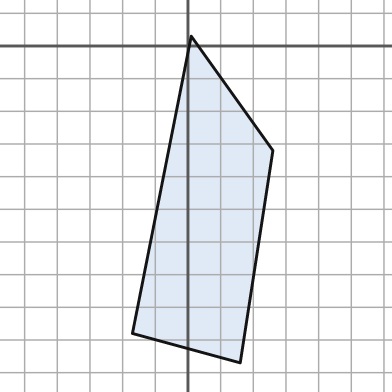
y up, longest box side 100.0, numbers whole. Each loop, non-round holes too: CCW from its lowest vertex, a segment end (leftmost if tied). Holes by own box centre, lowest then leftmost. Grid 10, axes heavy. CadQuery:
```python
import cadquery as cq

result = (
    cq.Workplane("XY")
    .moveTo(16.0, -97.0)
    .lineTo(26.0, -32.0)
    .lineTo(1.0, 3.0)
    .lineTo(-17.0, -88.0)
    .close()
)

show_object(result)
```